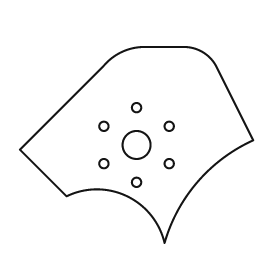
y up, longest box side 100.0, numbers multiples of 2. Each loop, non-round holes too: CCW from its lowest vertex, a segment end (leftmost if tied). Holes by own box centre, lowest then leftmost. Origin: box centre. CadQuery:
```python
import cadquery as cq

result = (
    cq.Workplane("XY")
    .moveTo(12.0, -42.0)
    .threePointArc((26.0, -16.0), (50.0, 2.0))
    .lineTo(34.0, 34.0)
    .threePointArc((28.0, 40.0), (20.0, 42.0))
    .lineTo(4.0, 42.0)
    .threePointArc((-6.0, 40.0), (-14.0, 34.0))
    .lineTo(-50.0, -2.0)
    .lineTo(-30.0, -22.0)
    .threePointArc((-4.0, -22.0), (12.0, -42.0))
    .close()
    .moveTo(0.0, -16.0)
    .circle(2.0)
    .moveTo(-14.0, -8.0)
    .circle(2.0)
    .moveTo(14.0, -8.0)
    .circle(2.0)
    .moveTo(0.0, 0.0)
    .circle(6.0)
    .moveTo(-14.0, 8.0)
    .circle(2.0)
    .moveTo(14.0, 8.0)
    .circle(2.0)
    .moveTo(0.0, 16.0)
    .circle(2.0)
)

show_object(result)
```